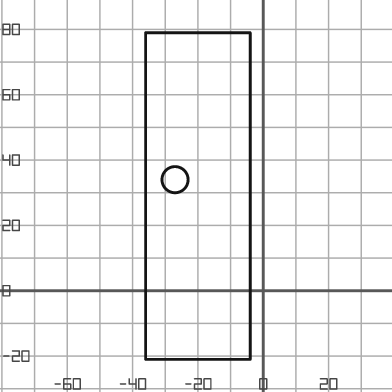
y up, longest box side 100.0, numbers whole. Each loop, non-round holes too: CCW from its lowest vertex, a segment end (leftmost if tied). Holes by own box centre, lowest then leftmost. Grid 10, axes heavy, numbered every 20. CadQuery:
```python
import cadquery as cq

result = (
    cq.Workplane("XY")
    .moveTo(-36.0, -21.0)
    .lineTo(-4.0, -21.0)
    .lineTo(-4.0, 79.0)
    .lineTo(-36.0, 79.0)
    .close()
    .moveTo(-27.0, 34.0)
    .circle(4.0)
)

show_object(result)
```